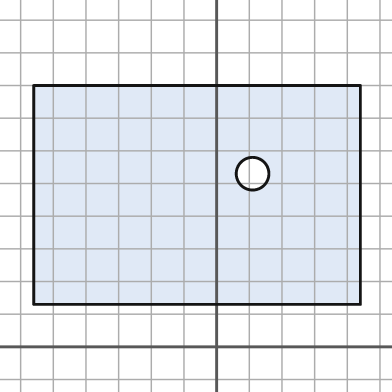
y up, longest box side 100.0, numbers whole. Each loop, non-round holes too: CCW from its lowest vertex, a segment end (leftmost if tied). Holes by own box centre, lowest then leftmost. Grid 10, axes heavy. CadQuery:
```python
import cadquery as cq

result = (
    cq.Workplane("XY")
    .moveTo(-56.0, 13.0)
    .lineTo(44.0, 13.0)
    .lineTo(44.0, 80.0)
    .lineTo(-56.0, 80.0)
    .close()
    .moveTo(11.0, 53.0)
    .circle(5.0)
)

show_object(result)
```